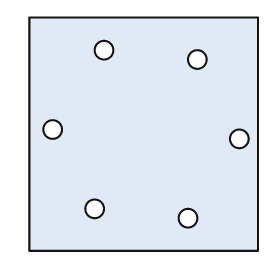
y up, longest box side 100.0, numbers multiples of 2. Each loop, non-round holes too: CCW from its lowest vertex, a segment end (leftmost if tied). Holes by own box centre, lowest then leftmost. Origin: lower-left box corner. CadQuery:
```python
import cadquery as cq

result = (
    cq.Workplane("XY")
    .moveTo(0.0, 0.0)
    .lineTo(98.0, 0.0)
    .lineTo(98.0, 100.0)
    .lineTo(0.0, 100.0)
    .close()
    .moveTo(68.0, 14.0)
    .circle(4.0)
    .moveTo(28.0, 18.0)
    .circle(4.0)
    .moveTo(90.0, 48.0)
    .circle(4.0)
    .moveTo(10.0, 52.0)
    .circle(4.0)
    .moveTo(72.0, 82.0)
    .circle(4.0)
    .moveTo(32.0, 86.0)
    .circle(4.0)
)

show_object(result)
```